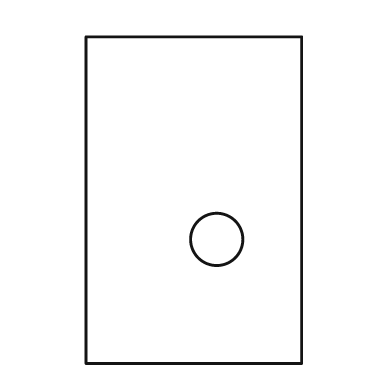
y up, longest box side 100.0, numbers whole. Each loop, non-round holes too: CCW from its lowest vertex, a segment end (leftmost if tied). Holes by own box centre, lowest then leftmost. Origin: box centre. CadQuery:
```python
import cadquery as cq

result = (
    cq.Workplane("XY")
    .moveTo(-33.0, -50.0)
    .lineTo(33.0, -50.0)
    .lineTo(33.0, 50.0)
    .lineTo(-33.0, 50.0)
    .close()
    .moveTo(7.0, -12.0)
    .circle(8.0)
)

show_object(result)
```